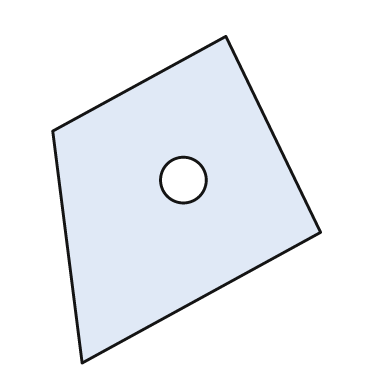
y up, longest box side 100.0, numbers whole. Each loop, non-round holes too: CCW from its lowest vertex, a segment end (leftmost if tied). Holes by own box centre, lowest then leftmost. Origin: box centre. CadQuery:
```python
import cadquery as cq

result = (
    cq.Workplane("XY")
    .moveTo(-32.0, -50.0)
    .lineTo(41.0, -10.0)
    .lineTo(12.0, 50.0)
    .lineTo(-41.0, 21.0)
    .close()
    .moveTo(-1.0, 6.0)
    .circle(7.0)
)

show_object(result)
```